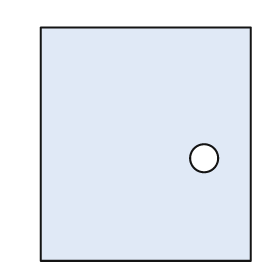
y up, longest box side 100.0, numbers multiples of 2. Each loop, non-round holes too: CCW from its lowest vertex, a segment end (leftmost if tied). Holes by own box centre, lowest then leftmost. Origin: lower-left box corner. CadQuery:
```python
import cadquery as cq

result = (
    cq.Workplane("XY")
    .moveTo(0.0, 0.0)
    .lineTo(90.0, 0.0)
    .lineTo(90.0, 100.0)
    .lineTo(0.0, 100.0)
    .close()
    .moveTo(70.0, 44.0)
    .circle(6.0)
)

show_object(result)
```